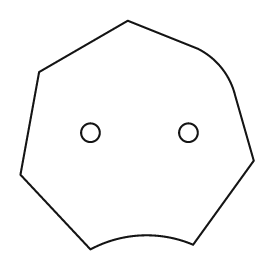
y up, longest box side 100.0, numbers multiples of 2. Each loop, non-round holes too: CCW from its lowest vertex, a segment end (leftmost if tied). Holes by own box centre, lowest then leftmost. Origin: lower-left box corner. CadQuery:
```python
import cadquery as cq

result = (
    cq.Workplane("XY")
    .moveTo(30.0, 0.0)
    .threePointArc((52.0, 6.0), (74.0, 2.0))
    .lineTo(100.0, 38.0)
    .lineTo(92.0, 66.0)
    .threePointArc((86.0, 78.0), (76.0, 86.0))
    .lineTo(46.0, 98.0)
    .lineTo(8.0, 76.0)
    .lineTo(0.0, 32.0)
    .close()
    .moveTo(30.0, 50.0)
    .circle(4.0)
    .moveTo(72.0, 50.0)
    .circle(4.0)
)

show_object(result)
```